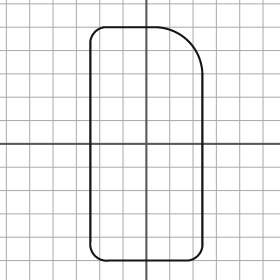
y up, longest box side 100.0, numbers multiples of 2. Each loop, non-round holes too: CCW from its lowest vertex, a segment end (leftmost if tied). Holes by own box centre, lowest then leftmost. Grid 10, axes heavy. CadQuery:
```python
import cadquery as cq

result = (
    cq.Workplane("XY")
    .moveTo(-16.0, -50.0)
    .lineTo(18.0, -50.0)
    .threePointArc((22.0, -48.0), (24.0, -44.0))
    .lineTo(24.0, 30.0)
    .threePointArc((18.0, 44.0), (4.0, 50.0))
    .lineTo(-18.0, 50.0)
    .threePointArc((-22.0, 48.0), (-24.0, 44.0))
    .lineTo(-24.0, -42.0)
    .threePointArc((-22.0, -48.0), (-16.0, -50.0))
    .close()
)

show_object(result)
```